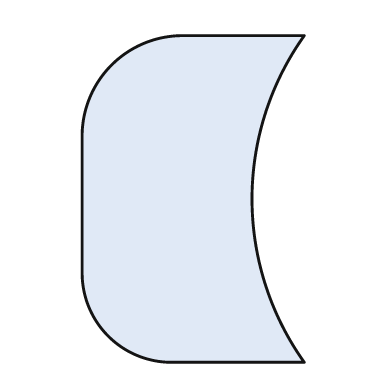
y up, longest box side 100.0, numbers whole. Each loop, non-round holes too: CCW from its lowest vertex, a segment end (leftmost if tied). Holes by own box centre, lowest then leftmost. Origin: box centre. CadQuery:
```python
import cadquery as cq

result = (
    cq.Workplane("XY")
    .moveTo(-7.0, -50.0)
    .lineTo(34.0, -50.0)
    .threePointArc((18.0, 0.0), (34.0, 50.0))
    .lineTo(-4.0, 50.0)
    .threePointArc((-25.0, 41.0), (-34.0, 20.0))
    .lineTo(-34.0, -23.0)
    .threePointArc((-26.0, -42.0), (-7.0, -50.0))
    .close()
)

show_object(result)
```